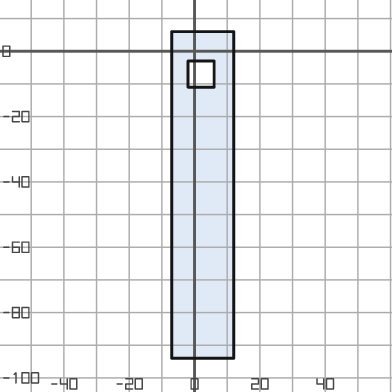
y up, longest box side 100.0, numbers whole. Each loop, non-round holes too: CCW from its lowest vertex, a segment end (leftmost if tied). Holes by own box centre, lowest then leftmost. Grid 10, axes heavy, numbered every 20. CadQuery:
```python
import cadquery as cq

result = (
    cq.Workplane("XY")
    .moveTo(-7.0, -94.0)
    .lineTo(12.0, -94.0)
    .lineTo(12.0, 6.0)
    .lineTo(-7.0, 6.0)
    .close()
    .moveTo(-2.0, -11.0)
    .lineTo(6.0, -11.0)
    .lineTo(6.0, -3.0)
    .lineTo(-2.0, -3.0)
    .close()
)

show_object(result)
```